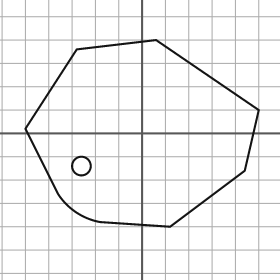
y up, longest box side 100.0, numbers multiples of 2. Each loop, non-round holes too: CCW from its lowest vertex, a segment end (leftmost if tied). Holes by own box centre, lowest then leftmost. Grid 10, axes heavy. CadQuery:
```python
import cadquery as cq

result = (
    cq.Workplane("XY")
    .moveTo(12.0, -40.0)
    .lineTo(44.0, -16.0)
    .lineTo(50.0, 10.0)
    .lineTo(6.0, 40.0)
    .lineTo(-28.0, 36.0)
    .lineTo(-50.0, 2.0)
    .lineTo(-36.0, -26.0)
    .threePointArc((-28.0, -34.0), (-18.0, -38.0))
    .close()
    .moveTo(-26.0, -14.0)
    .circle(4.0)
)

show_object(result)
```